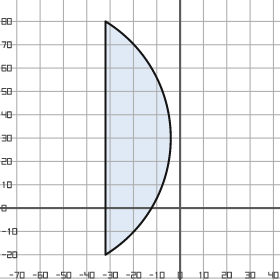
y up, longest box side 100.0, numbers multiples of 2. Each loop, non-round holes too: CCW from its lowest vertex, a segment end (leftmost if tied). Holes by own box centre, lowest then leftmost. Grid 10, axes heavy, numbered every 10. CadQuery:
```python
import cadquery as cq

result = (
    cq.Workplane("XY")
    .moveTo(-32.0, -20.0)
    .threePointArc((-4.0, 30.0), (-32.0, 80.0))
    .close()
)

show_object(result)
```